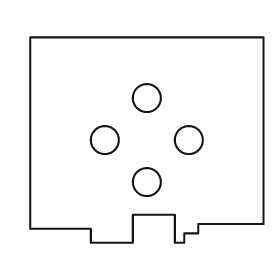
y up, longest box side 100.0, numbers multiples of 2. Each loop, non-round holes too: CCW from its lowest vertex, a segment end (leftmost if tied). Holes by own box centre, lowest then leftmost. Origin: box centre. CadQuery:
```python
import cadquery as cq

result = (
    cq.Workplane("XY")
    .moveTo(-24.0, -44.0)
    .lineTo(-6.0, -44.0)
    .lineTo(-6.0, -32.0)
    .lineTo(12.0, -32.0)
    .lineTo(12.0, -44.0)
    .lineTo(16.0, -44.0)
    .lineTo(16.0, -40.0)
    .lineTo(22.0, -40.0)
    .lineTo(22.0, -36.0)
    .lineTo(50.0, -36.0)
    .lineTo(50.0, 44.0)
    .lineTo(-50.0, 44.0)
    .lineTo(-50.0, -38.0)
    .lineTo(-24.0, -38.0)
    .close()
    .moveTo(0.0, -18.0)
    .circle(6.0)
    .moveTo(-18.0, 0.0)
    .circle(6.0)
    .moveTo(18.0, 0.0)
    .circle(6.0)
    .moveTo(0.0, 18.0)
    .circle(6.0)
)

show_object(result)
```